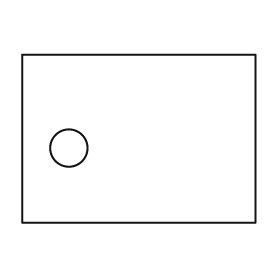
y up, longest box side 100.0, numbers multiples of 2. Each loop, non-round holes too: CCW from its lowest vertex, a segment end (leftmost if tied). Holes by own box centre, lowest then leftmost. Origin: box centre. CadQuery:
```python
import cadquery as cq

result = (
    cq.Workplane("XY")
    .moveTo(-50.0, -36.0)
    .lineTo(50.0, -36.0)
    .lineTo(50.0, 36.0)
    .lineTo(-50.0, 36.0)
    .close()
    .moveTo(-30.0, -4.0)
    .circle(8.0)
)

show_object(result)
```